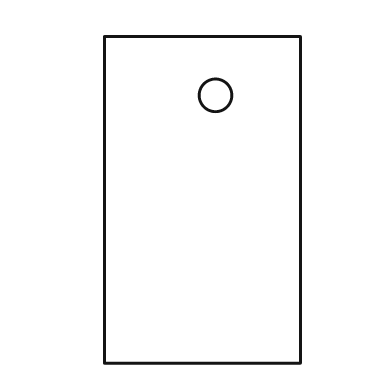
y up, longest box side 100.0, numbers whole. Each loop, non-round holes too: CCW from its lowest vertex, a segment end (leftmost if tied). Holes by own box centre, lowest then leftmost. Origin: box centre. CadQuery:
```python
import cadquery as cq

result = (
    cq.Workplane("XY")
    .moveTo(-30.0, -50.0)
    .lineTo(30.0, -50.0)
    .lineTo(30.0, 50.0)
    .lineTo(-30.0, 50.0)
    .close()
    .moveTo(4.0, 32.0)
    .circle(5.0)
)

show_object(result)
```